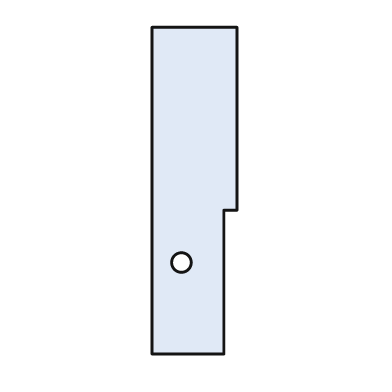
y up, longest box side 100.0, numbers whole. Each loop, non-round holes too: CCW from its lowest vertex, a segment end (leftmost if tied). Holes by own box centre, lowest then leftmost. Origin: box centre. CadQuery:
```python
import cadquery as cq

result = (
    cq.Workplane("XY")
    .moveTo(-13.0, -50.0)
    .lineTo(9.0, -50.0)
    .lineTo(9.0, -6.0)
    .lineTo(13.0, -6.0)
    .lineTo(13.0, 50.0)
    .lineTo(-13.0, 50.0)
    .close()
    .moveTo(-4.0, -22.0)
    .circle(3.0)
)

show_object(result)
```